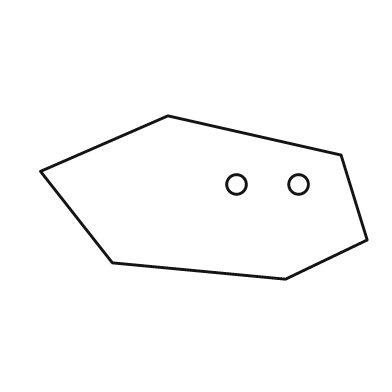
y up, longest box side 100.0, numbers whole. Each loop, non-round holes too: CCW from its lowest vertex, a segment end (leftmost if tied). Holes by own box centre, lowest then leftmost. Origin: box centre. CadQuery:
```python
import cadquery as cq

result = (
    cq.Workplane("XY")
    .moveTo(25.0, -25.0)
    .lineTo(50.0, -13.0)
    .lineTo(42.0, 13.0)
    .lineTo(-11.0, 25.0)
    .lineTo(-50.0, 8.0)
    .lineTo(-28.0, -20.0)
    .close()
    .moveTo(10.0, 4.0)
    .circle(3.0)
    .moveTo(29.0, 4.0)
    .circle(3.0)
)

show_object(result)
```